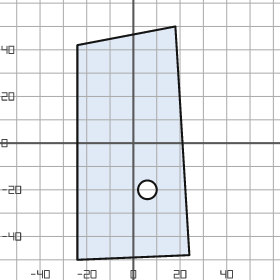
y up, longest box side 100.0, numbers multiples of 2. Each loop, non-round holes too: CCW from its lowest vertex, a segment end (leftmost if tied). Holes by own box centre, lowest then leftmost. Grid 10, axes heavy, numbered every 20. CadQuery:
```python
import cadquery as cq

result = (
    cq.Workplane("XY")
    .moveTo(-24.0, -50.0)
    .lineTo(24.0, -48.0)
    .lineTo(18.0, 50.0)
    .lineTo(-24.0, 42.0)
    .close()
    .moveTo(6.0, -20.0)
    .circle(4.0)
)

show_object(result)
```